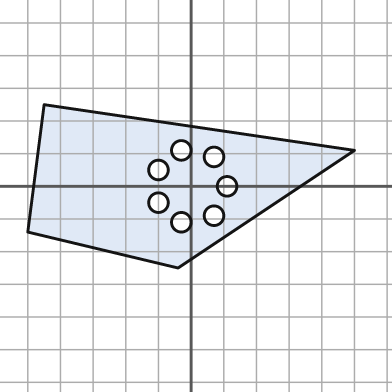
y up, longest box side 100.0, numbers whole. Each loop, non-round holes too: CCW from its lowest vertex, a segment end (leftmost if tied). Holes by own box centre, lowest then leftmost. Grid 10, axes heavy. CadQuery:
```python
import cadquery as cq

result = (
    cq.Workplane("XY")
    .moveTo(-4.0, -25.0)
    .lineTo(50.0, 11.0)
    .lineTo(-45.0, 25.0)
    .lineTo(-50.0, -14.0)
    .close()
    .moveTo(-3.0, -11.0)
    .circle(3.0)
    .moveTo(7.0, -9.0)
    .circle(3.0)
    .moveTo(-10.0, -5.0)
    .circle(3.0)
    .moveTo(11.0, 0.0)
    .circle(3.0)
    .moveTo(-10.0, 5.0)
    .circle(3.0)
    .moveTo(7.0, 9.0)
    .circle(3.0)
    .moveTo(-3.0, 11.0)
    .circle(3.0)
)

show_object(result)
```